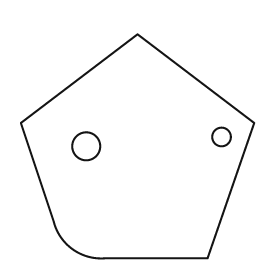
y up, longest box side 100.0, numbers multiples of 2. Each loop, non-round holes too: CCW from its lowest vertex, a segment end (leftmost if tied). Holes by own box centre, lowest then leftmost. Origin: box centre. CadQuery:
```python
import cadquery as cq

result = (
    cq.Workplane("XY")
    .moveTo(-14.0, -48.0)
    .lineTo(30.0, -48.0)
    .lineTo(50.0, 10.0)
    .lineTo(0.0, 48.0)
    .lineTo(-50.0, 10.0)
    .lineTo(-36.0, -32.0)
    .threePointArc((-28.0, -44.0), (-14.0, -48.0))
    .close()
    .moveTo(-22.0, 0.0)
    .circle(6.0)
    .moveTo(36.0, 4.0)
    .circle(4.0)
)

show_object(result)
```